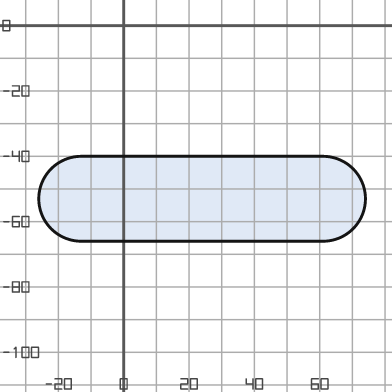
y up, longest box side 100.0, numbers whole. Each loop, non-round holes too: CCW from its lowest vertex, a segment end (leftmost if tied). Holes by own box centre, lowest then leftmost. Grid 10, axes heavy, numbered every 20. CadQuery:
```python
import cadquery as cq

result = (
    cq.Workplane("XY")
    .moveTo(-13.0, -66.0)
    .lineTo(61.0, -66.0)
    .threePointArc((74.0, -53.0), (61.0, -40.0))
    .lineTo(-13.0, -40.0)
    .threePointArc((-26.0, -53.0), (-13.0, -66.0))
    .close()
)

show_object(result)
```